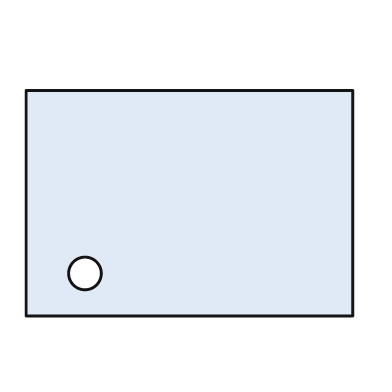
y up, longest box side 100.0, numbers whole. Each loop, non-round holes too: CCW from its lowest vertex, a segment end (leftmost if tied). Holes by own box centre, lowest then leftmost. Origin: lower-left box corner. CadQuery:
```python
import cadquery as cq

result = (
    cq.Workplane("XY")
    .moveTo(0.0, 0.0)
    .lineTo(100.0, 0.0)
    .lineTo(100.0, 69.0)
    .lineTo(0.0, 69.0)
    .close()
    .moveTo(18.0, 13.0)
    .circle(5.0)
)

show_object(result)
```